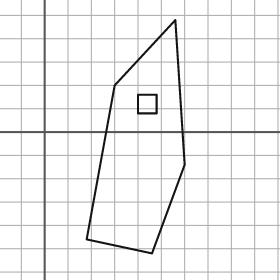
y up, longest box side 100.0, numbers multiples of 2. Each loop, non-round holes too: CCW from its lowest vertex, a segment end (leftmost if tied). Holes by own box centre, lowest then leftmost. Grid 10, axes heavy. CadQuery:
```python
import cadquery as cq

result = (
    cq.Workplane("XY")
    .moveTo(46.0, -52.0)
    .lineTo(60.0, -14.0)
    .lineTo(56.0, 48.0)
    .lineTo(30.0, 20.0)
    .lineTo(18.0, -46.0)
    .close()
    .moveTo(40.0, 8.0)
    .lineTo(48.0, 8.0)
    .lineTo(48.0, 16.0)
    .lineTo(40.0, 16.0)
    .close()
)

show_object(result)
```